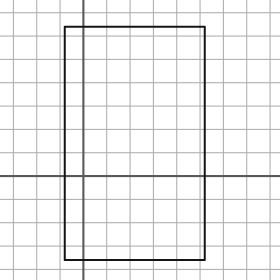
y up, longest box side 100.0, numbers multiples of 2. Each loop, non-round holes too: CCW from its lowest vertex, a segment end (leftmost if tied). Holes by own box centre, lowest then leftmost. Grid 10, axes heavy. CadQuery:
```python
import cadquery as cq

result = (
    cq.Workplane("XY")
    .moveTo(-8.0, -36.0)
    .lineTo(52.0, -36.0)
    .lineTo(52.0, 64.0)
    .lineTo(-8.0, 64.0)
    .close()
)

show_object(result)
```